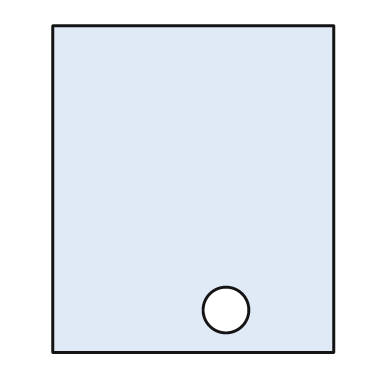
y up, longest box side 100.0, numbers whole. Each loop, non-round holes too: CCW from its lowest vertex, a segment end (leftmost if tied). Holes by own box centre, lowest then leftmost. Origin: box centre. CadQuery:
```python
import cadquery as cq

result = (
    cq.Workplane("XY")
    .moveTo(-43.0, -50.0)
    .lineTo(43.0, -50.0)
    .lineTo(43.0, 50.0)
    .lineTo(-43.0, 50.0)
    .close()
    .moveTo(10.0, -37.0)
    .circle(7.0)
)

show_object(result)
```